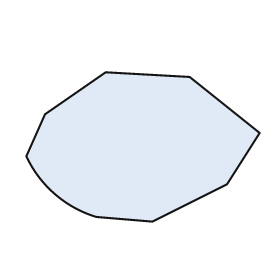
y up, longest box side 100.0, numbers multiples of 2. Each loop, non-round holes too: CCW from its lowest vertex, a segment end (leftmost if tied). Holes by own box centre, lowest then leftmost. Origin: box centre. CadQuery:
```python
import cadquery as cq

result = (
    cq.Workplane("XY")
    .moveTo(4.0, -32.0)
    .lineTo(36.0, -16.0)
    .lineTo(50.0, 6.0)
    .lineTo(20.0, 30.0)
    .lineTo(-16.0, 32.0)
    .lineTo(-42.0, 14.0)
    .lineTo(-50.0, -4.0)
    .threePointArc((-38.0, -20.0), (-20.0, -30.0))
    .close()
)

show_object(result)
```